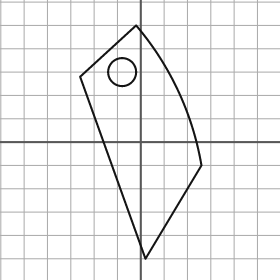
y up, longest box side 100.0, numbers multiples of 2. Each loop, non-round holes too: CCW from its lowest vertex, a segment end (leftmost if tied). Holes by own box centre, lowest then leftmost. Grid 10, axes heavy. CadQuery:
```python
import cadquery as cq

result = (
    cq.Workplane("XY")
    .moveTo(2.0, -50.0)
    .lineTo(26.0, -10.0)
    .threePointArc((16.0, 22.0), (-2.0, 50.0))
    .lineTo(-26.0, 28.0)
    .close()
    .moveTo(-8.0, 30.0)
    .circle(6.0)
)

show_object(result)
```